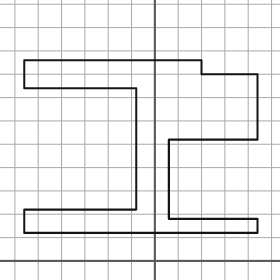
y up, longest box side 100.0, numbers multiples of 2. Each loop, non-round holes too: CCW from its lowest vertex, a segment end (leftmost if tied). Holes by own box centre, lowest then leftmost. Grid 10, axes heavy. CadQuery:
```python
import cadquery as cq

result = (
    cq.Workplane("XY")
    .moveTo(-56.0, 12.0)
    .lineTo(44.0, 12.0)
    .lineTo(44.0, 18.0)
    .lineTo(6.0, 18.0)
    .lineTo(6.0, 52.0)
    .lineTo(44.0, 52.0)
    .lineTo(44.0, 80.0)
    .lineTo(20.0, 80.0)
    .lineTo(20.0, 86.0)
    .lineTo(-56.0, 86.0)
    .lineTo(-56.0, 74.0)
    .lineTo(-8.0, 74.0)
    .lineTo(-8.0, 22.0)
    .lineTo(-56.0, 22.0)
    .close()
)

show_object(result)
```